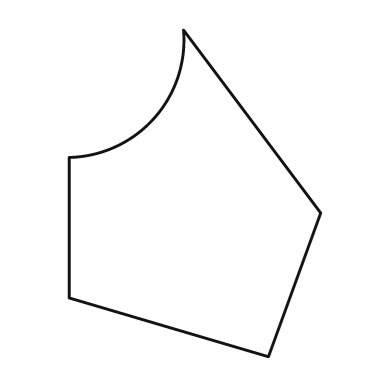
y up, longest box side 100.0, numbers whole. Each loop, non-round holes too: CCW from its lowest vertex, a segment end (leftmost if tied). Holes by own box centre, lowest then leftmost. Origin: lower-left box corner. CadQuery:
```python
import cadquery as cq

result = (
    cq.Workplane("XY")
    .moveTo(61.0, 0.0)
    .lineTo(77.0, 44.0)
    .lineTo(35.0, 100.0)
    .threePointArc((26.0, 73.0), (0.0, 61.0))
    .lineTo(0.0, 18.0)
    .close()
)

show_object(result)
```